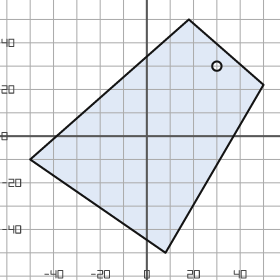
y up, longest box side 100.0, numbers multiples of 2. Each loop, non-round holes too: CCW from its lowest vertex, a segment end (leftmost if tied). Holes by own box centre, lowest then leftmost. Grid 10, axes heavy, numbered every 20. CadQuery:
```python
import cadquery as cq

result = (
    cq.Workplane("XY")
    .moveTo(8.0, -50.0)
    .lineTo(50.0, 22.0)
    .lineTo(18.0, 50.0)
    .lineTo(-50.0, -10.0)
    .close()
    .moveTo(30.0, 30.0)
    .circle(2.0)
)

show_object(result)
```